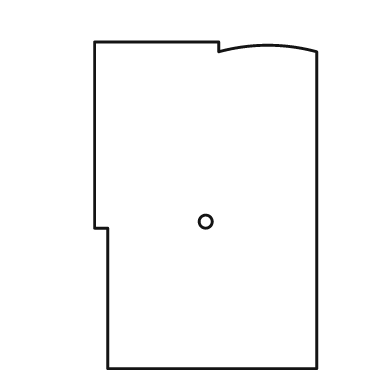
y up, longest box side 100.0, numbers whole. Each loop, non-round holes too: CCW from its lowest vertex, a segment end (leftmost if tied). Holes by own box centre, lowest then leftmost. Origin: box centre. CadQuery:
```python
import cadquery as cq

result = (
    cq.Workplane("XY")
    .moveTo(-30.0, -50.0)
    .lineTo(34.0, -50.0)
    .lineTo(34.0, 47.0)
    .threePointArc((19.0, 49.0), (4.0, 47.0))
    .lineTo(4.0, 50.0)
    .lineTo(-34.0, 50.0)
    .lineTo(-34.0, -7.0)
    .lineTo(-30.0, -7.0)
    .close()
    .moveTo(0.0, -5.0)
    .circle(2.0)
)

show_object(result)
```